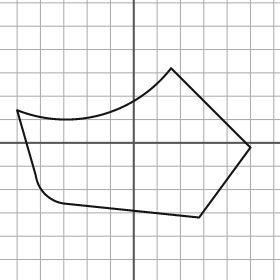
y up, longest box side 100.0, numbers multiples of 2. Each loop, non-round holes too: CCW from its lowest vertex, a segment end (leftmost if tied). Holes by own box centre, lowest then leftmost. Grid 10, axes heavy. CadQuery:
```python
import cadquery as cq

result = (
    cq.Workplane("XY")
    .moveTo(28.0, -32.0)
    .lineTo(50.0, -2.0)
    .lineTo(16.0, 32.0)
    .threePointArc((-14.0, 12.0), (-50.0, 14.0))
    .lineTo(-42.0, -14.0)
    .threePointArc((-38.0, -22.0), (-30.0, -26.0))
    .close()
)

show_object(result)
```